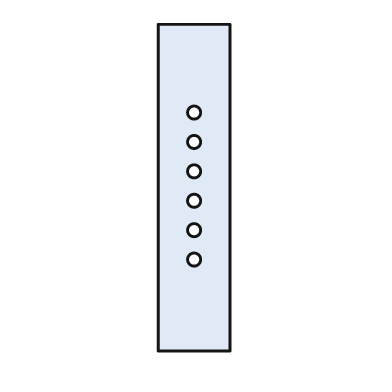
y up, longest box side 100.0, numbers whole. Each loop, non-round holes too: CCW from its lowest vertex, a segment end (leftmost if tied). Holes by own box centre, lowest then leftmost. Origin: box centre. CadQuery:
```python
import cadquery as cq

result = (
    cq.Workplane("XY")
    .moveTo(-11.0, -50.0)
    .lineTo(11.0, -50.0)
    .lineTo(11.0, 50.0)
    .lineTo(-11.0, 50.0)
    .close()
    .moveTo(0.0, -22.0)
    .circle(2.0)
    .moveTo(0.0, -13.0)
    .circle(2.0)
    .moveTo(0.0, -4.0)
    .circle(2.0)
    .moveTo(0.0, 5.0)
    .circle(2.0)
    .moveTo(0.0, 14.0)
    .circle(2.0)
    .moveTo(0.0, 23.0)
    .circle(2.0)
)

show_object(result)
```